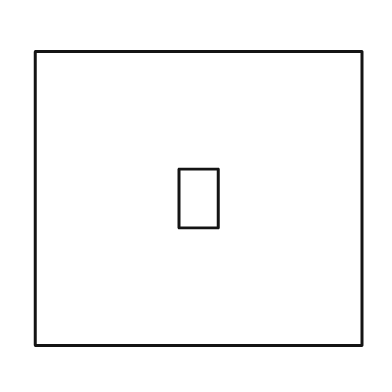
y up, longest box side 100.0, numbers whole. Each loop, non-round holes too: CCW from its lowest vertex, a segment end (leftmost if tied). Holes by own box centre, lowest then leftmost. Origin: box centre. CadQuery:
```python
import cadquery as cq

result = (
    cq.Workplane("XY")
    .moveTo(-50.0, -45.0)
    .lineTo(50.0, -45.0)
    .lineTo(50.0, 45.0)
    .lineTo(-50.0, 45.0)
    .close()
    .moveTo(-6.0, -9.0)
    .lineTo(6.0, -9.0)
    .lineTo(6.0, 9.0)
    .lineTo(-6.0, 9.0)
    .close()
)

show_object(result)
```